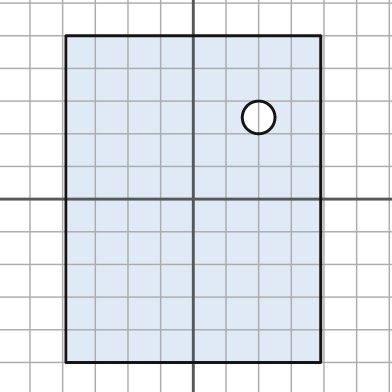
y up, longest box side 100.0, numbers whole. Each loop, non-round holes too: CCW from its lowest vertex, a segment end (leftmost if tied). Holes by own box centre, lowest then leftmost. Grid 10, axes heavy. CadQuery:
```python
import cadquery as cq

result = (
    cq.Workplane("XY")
    .moveTo(-39.0, -50.0)
    .lineTo(39.0, -50.0)
    .lineTo(39.0, 50.0)
    .lineTo(-39.0, 50.0)
    .close()
    .moveTo(20.0, 25.0)
    .circle(5.0)
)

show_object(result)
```